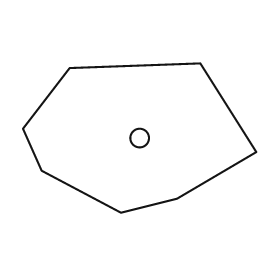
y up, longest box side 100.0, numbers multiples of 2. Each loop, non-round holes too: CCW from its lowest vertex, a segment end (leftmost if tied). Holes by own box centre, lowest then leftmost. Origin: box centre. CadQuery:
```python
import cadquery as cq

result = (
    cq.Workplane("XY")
    .moveTo(-8.0, -32.0)
    .lineTo(16.0, -26.0)
    .lineTo(50.0, -6.0)
    .lineTo(26.0, 32.0)
    .lineTo(-30.0, 30.0)
    .lineTo(-50.0, 4.0)
    .lineTo(-42.0, -14.0)
    .close()
    .moveTo(0.0, 0.0)
    .circle(4.0)
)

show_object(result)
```